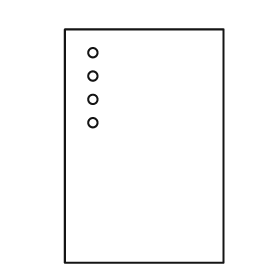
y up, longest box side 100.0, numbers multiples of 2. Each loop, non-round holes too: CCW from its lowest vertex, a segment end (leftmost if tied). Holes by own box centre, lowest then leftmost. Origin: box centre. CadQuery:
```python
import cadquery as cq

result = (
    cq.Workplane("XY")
    .moveTo(-34.0, -50.0)
    .lineTo(34.0, -50.0)
    .lineTo(34.0, 50.0)
    .lineTo(-34.0, 50.0)
    .close()
    .moveTo(-22.0, 10.0)
    .circle(2.0)
    .moveTo(-22.0, 20.0)
    .circle(2.0)
    .moveTo(-22.0, 30.0)
    .circle(2.0)
    .moveTo(-22.0, 40.0)
    .circle(2.0)
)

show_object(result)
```